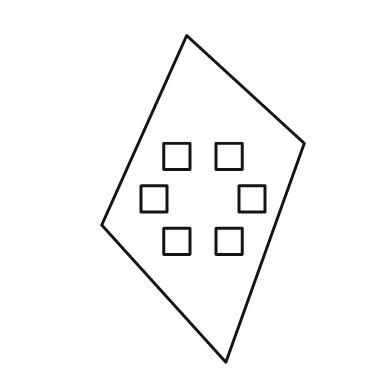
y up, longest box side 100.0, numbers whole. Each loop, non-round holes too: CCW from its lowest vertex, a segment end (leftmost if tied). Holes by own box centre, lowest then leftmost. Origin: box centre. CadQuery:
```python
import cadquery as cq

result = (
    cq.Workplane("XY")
    .moveTo(7.0, -50.0)
    .lineTo(31.0, 17.0)
    .lineTo(-5.0, 50.0)
    .lineTo(-31.0, -8.0)
    .close()
    .moveTo(-12.0, -17.0)
    .lineTo(-4.0, -17.0)
    .lineTo(-4.0, -9.0)
    .lineTo(-12.0, -9.0)
    .close()
    .moveTo(4.0, -17.0)
    .lineTo(12.0, -17.0)
    .lineTo(12.0, -9.0)
    .lineTo(4.0, -9.0)
    .close()
    .moveTo(-19.0, -4.0)
    .lineTo(-11.0, -4.0)
    .lineTo(-11.0, 4.0)
    .lineTo(-19.0, 4.0)
    .close()
    .moveTo(11.0, -4.0)
    .lineTo(19.0, -4.0)
    .lineTo(19.0, 4.0)
    .lineTo(11.0, 4.0)
    .close()
    .moveTo(-12.0, 9.0)
    .lineTo(-4.0, 9.0)
    .lineTo(-4.0, 17.0)
    .lineTo(-12.0, 17.0)
    .close()
    .moveTo(4.0, 9.0)
    .lineTo(12.0, 9.0)
    .lineTo(12.0, 17.0)
    .lineTo(4.0, 17.0)
    .close()
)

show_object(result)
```